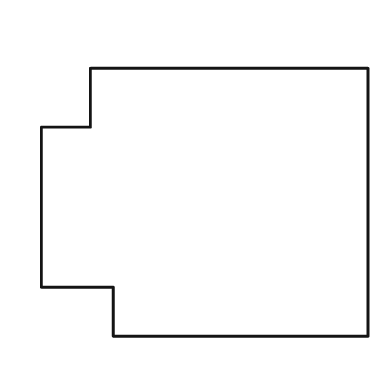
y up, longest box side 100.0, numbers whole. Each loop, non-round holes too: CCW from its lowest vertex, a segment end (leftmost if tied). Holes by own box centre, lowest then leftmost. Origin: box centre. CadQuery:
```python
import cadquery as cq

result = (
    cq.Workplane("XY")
    .moveTo(-28.0, -41.0)
    .lineTo(50.0, -41.0)
    .lineTo(50.0, 41.0)
    .lineTo(-35.0, 41.0)
    .lineTo(-35.0, 23.0)
    .lineTo(-50.0, 23.0)
    .lineTo(-50.0, -26.0)
    .lineTo(-28.0, -26.0)
    .close()
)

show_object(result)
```